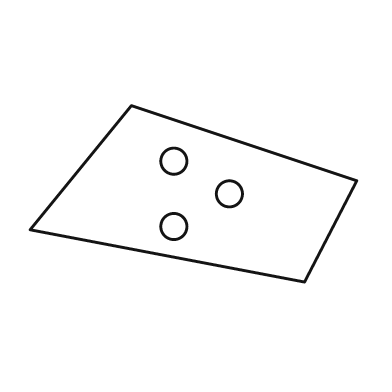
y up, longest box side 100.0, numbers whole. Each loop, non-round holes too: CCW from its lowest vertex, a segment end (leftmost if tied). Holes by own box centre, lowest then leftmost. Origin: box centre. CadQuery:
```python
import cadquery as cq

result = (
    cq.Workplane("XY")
    .moveTo(34.0, -27.0)
    .lineTo(50.0, 4.0)
    .lineTo(-19.0, 27.0)
    .lineTo(-50.0, -11.0)
    .close()
    .moveTo(-6.0, -10.0)
    .circle(4.0)
    .moveTo(11.0, 0.0)
    .circle(4.0)
    .moveTo(-6.0, 10.0)
    .circle(4.0)
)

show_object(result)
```